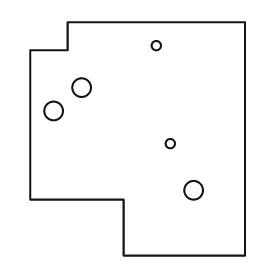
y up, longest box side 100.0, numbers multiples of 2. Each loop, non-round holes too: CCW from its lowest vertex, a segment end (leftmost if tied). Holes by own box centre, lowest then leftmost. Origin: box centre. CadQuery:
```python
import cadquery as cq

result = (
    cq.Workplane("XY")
    .moveTo(-6.0, -50.0)
    .lineTo(46.0, -50.0)
    .lineTo(46.0, 50.0)
    .lineTo(-30.0, 50.0)
    .lineTo(-30.0, 38.0)
    .lineTo(-46.0, 38.0)
    .lineTo(-46.0, -26.0)
    .lineTo(-6.0, -26.0)
    .close()
    .moveTo(24.0, -22.0)
    .circle(4.0)
    .moveTo(14.0, -2.0)
    .circle(2.0)
    .moveTo(-36.0, 12.0)
    .circle(4.0)
    .moveTo(-24.0, 22.0)
    .circle(4.0)
    .moveTo(8.0, 40.0)
    .circle(2.0)
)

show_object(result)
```